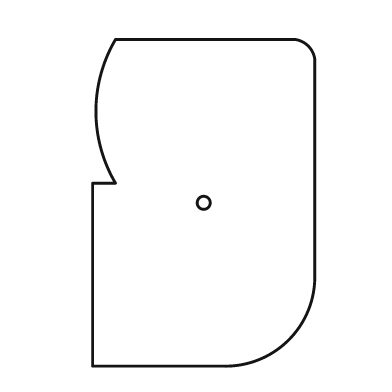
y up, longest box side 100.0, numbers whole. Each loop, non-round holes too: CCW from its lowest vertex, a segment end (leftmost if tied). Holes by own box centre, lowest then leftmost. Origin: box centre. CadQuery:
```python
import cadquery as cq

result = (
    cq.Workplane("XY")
    .moveTo(-34.0, -50.0)
    .lineTo(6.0, -50.0)
    .threePointArc((26.0, -42.0), (34.0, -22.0))
    .lineTo(34.0, 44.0)
    .threePointArc((32.0, 48.0), (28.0, 50.0))
    .lineTo(-27.0, 50.0)
    .threePointArc((-33.0, 28.0), (-27.0, 6.0))
    .lineTo(-34.0, 6.0)
    .close()
    .moveTo(0.0, 0.0)
    .circle(2.0)
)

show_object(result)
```